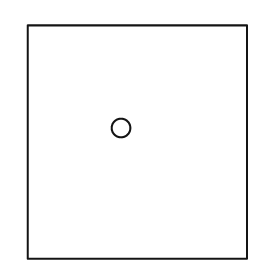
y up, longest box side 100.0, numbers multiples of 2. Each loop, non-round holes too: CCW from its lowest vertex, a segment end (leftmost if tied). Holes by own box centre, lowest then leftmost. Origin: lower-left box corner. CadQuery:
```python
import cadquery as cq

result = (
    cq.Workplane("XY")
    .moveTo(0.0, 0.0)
    .lineTo(94.0, 0.0)
    .lineTo(94.0, 100.0)
    .lineTo(0.0, 100.0)
    .close()
    .moveTo(40.0, 56.0)
    .circle(4.0)
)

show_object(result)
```